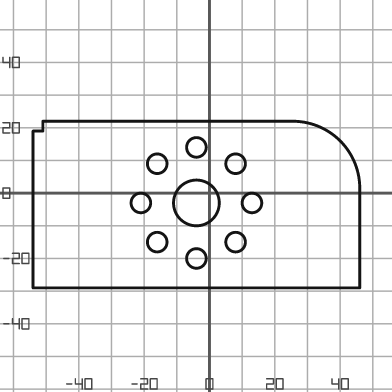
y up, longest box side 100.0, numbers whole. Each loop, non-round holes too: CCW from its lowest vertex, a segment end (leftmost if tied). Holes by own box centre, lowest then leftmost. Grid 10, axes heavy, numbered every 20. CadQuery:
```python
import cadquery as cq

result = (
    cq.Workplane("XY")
    .moveTo(-54.0, -29.0)
    .lineTo(46.0, -29.0)
    .lineTo(46.0, 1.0)
    .threePointArc((40.0, 16.0), (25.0, 22.0))
    .lineTo(-51.0, 22.0)
    .lineTo(-51.0, 19.0)
    .lineTo(-54.0, 19.0)
    .close()
    .moveTo(-4.0, -20.0)
    .circle(3.0)
    .moveTo(-16.0, -15.0)
    .circle(3.0)
    .moveTo(8.0, -15.0)
    .circle(3.0)
    .moveTo(-21.0, -3.0)
    .circle(3.0)
    .moveTo(-4.0, -3.0)
    .circle(7.0)
    .moveTo(13.0, -3.0)
    .circle(3.0)
    .moveTo(-16.0, 9.0)
    .circle(3.0)
    .moveTo(8.0, 9.0)
    .circle(3.0)
    .moveTo(-4.0, 14.0)
    .circle(3.0)
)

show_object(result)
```